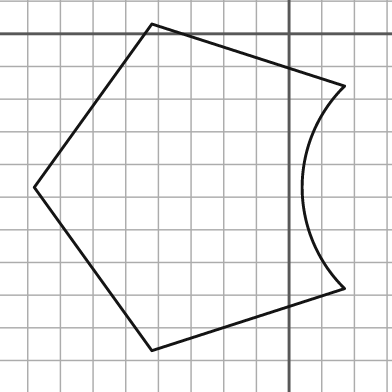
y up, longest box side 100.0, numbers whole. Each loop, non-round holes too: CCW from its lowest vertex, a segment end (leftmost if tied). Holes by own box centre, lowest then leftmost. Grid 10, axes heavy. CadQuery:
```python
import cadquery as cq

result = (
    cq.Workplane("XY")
    .moveTo(-42.0, -97.0)
    .lineTo(17.0, -78.0)
    .threePointArc((4.0, -47.0), (17.0, -16.0))
    .lineTo(-42.0, 3.0)
    .lineTo(-78.0, -47.0)
    .close()
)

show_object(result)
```